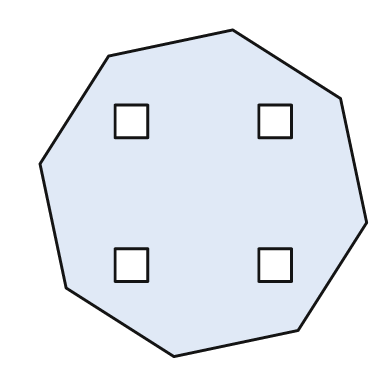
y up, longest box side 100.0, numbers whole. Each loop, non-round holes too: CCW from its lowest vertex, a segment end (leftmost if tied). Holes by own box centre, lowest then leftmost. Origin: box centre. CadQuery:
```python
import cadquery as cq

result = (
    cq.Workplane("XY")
    .moveTo(-9.0, -50.0)
    .lineTo(29.0, -42.0)
    .lineTo(50.0, -9.0)
    .lineTo(42.0, 29.0)
    .lineTo(9.0, 50.0)
    .lineTo(-29.0, 42.0)
    .lineTo(-50.0, 9.0)
    .lineTo(-42.0, -29.0)
    .close()
    .moveTo(-27.0, -27.0)
    .lineTo(-17.0, -27.0)
    .lineTo(-17.0, -17.0)
    .lineTo(-27.0, -17.0)
    .close()
    .moveTo(17.0, -27.0)
    .lineTo(27.0, -27.0)
    .lineTo(27.0, -17.0)
    .lineTo(17.0, -17.0)
    .close()
    .moveTo(-27.0, 17.0)
    .lineTo(-17.0, 17.0)
    .lineTo(-17.0, 27.0)
    .lineTo(-27.0, 27.0)
    .close()
    .moveTo(17.0, 17.0)
    .lineTo(27.0, 17.0)
    .lineTo(27.0, 27.0)
    .lineTo(17.0, 27.0)
    .close()
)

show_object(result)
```